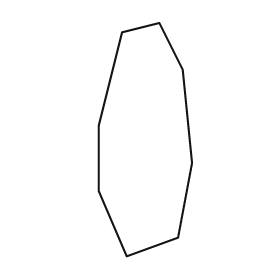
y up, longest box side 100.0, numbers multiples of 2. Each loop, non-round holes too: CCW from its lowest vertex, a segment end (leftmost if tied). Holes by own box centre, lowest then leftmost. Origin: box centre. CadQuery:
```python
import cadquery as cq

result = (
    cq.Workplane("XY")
    .moveTo(-8.0, -50.0)
    .lineTo(14.0, -42.0)
    .lineTo(20.0, -10.0)
    .lineTo(16.0, 30.0)
    .lineTo(6.0, 50.0)
    .lineTo(-10.0, 46.0)
    .lineTo(-20.0, 6.0)
    .lineTo(-20.0, -22.0)
    .close()
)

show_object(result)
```